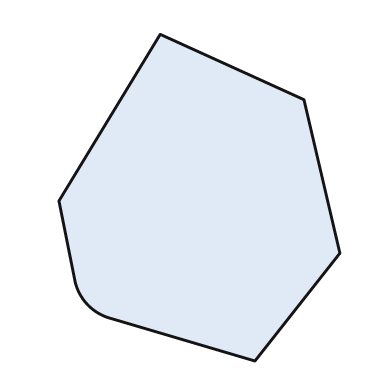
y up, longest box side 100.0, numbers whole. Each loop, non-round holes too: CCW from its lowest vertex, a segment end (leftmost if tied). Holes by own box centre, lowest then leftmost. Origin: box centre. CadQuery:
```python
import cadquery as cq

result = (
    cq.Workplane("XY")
    .moveTo(17.0, -50.0)
    .lineTo(43.0, -17.0)
    .lineTo(32.0, 30.0)
    .lineTo(-12.0, 50.0)
    .lineTo(-43.0, -1.0)
    .lineTo(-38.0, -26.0)
    .threePointArc((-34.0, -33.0), (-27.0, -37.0))
    .close()
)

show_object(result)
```